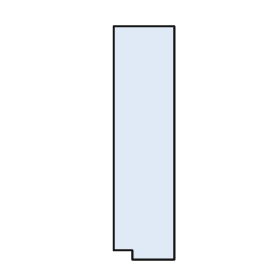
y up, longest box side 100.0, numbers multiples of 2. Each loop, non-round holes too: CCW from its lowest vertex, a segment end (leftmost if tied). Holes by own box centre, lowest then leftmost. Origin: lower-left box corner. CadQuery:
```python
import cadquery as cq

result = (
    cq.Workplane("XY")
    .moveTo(8.0, 0.0)
    .lineTo(26.0, 0.0)
    .lineTo(26.0, 100.0)
    .lineTo(0.0, 100.0)
    .lineTo(0.0, 4.0)
    .lineTo(8.0, 4.0)
    .close()
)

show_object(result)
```